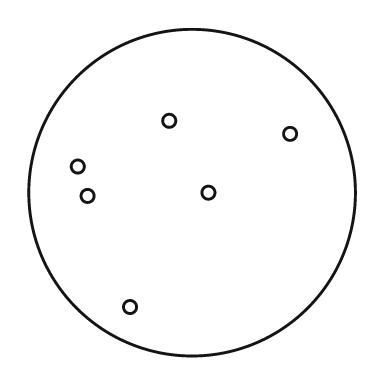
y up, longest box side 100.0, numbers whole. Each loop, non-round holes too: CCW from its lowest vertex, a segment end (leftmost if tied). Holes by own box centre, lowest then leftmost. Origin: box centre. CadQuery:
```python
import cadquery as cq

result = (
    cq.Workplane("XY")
    .moveTo(0.0, 0.0)
    .circle(50.0)
    .moveTo(-19.0, -35.0)
    .circle(2.0)
    .moveTo(-32.0, -1.0)
    .circle(2.0)
    .moveTo(5.0, 0.0)
    .circle(2.0)
    .moveTo(-35.0, 8.0)
    .circle(2.0)
    .moveTo(30.0, 18.0)
    .circle(2.0)
    .moveTo(-7.0, 22.0)
    .circle(2.0)
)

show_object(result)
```